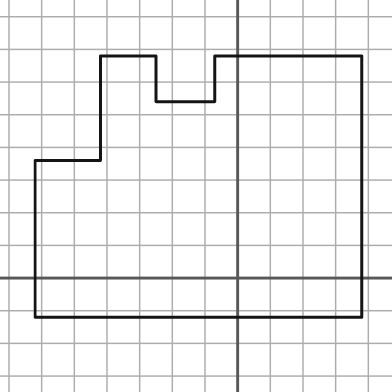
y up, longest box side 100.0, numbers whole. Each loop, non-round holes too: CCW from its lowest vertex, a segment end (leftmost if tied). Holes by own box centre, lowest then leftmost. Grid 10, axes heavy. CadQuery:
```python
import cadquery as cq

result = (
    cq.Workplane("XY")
    .moveTo(-62.0, -12.0)
    .lineTo(38.0, -12.0)
    .lineTo(38.0, 68.0)
    .lineTo(-7.0, 68.0)
    .lineTo(-7.0, 54.0)
    .lineTo(-25.0, 54.0)
    .lineTo(-25.0, 68.0)
    .lineTo(-42.0, 68.0)
    .lineTo(-42.0, 36.0)
    .lineTo(-62.0, 36.0)
    .close()
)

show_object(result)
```